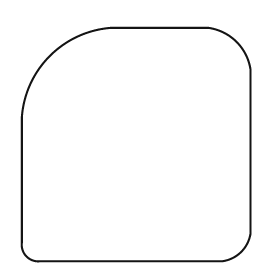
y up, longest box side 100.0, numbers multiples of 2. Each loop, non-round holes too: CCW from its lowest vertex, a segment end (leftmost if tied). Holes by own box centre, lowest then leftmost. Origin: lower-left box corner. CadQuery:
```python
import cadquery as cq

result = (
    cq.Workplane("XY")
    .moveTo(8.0, 0.0)
    .lineTo(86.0, 0.0)
    .threePointArc((94.0, 4.0), (98.0, 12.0))
    .lineTo(98.0, 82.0)
    .threePointArc((92.0, 94.0), (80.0, 100.0))
    .lineTo(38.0, 100.0)
    .threePointArc((12.0, 88.0), (0.0, 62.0))
    .lineTo(0.0, 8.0)
    .threePointArc((2.0, 2.0), (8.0, 0.0))
    .close()
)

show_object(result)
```